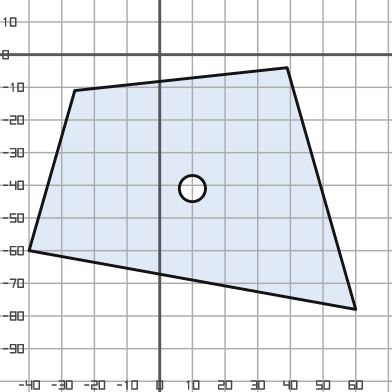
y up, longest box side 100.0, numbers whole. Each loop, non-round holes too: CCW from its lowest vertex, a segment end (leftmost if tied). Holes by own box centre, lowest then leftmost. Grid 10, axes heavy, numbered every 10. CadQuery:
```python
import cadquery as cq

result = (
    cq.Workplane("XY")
    .moveTo(60.0, -78.0)
    .lineTo(39.0, -4.0)
    .lineTo(-26.0, -11.0)
    .lineTo(-40.0, -60.0)
    .close()
    .moveTo(10.0, -41.0)
    .circle(4.0)
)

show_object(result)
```